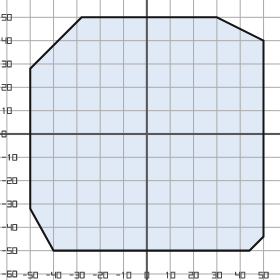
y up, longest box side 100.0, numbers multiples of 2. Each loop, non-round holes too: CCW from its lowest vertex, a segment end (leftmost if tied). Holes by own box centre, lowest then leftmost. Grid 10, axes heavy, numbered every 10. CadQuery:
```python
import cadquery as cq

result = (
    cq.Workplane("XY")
    .moveTo(-40.0, -50.0)
    .lineTo(44.0, -50.0)
    .lineTo(50.0, -44.0)
    .lineTo(50.0, 40.0)
    .lineTo(30.0, 50.0)
    .lineTo(-28.0, 50.0)
    .lineTo(-50.0, 28.0)
    .lineTo(-50.0, -32.0)
    .close()
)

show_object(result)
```